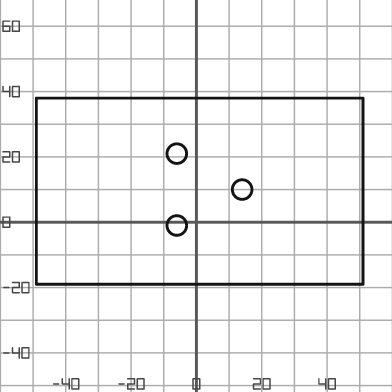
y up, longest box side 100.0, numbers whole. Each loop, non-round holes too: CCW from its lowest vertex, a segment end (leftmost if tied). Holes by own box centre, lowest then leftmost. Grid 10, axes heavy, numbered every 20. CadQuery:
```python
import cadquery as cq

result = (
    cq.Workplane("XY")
    .moveTo(-49.0, -19.0)
    .lineTo(51.0, -19.0)
    .lineTo(51.0, 38.0)
    .lineTo(-49.0, 38.0)
    .close()
    .moveTo(-6.0, -1.0)
    .circle(3.0)
    .moveTo(14.0, 10.0)
    .circle(3.0)
    .moveTo(-6.0, 21.0)
    .circle(3.0)
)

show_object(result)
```